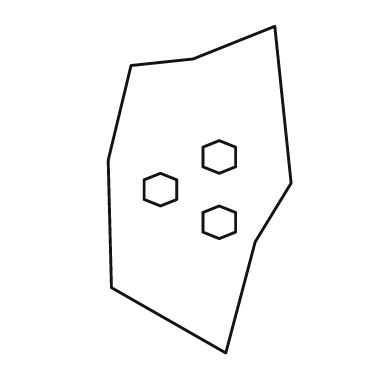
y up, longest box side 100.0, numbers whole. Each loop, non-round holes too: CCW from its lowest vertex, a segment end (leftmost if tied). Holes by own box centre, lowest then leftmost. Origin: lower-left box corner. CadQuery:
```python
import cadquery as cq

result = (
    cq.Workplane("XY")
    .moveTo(36.0, 0.0)
    .lineTo(45.0, 34.0)
    .lineTo(56.0, 52.0)
    .lineTo(51.0, 100.0)
    .lineTo(26.0, 90.0)
    .lineTo(7.0, 88.0)
    .lineTo(0.0, 59.0)
    .lineTo(1.0, 20.0)
    .close()
    .moveTo(34.0, 35.0)
    .lineTo(39.0, 37.0)
    .lineTo(39.0, 43.0)
    .lineTo(34.0, 45.0)
    .lineTo(29.0, 43.0)
    .lineTo(29.0, 37.0)
    .close()
    .moveTo(16.0, 45.0)
    .lineTo(21.0, 47.0)
    .lineTo(21.0, 53.0)
    .lineTo(16.0, 55.0)
    .lineTo(11.0, 53.0)
    .lineTo(11.0, 47.0)
    .close()
    .moveTo(34.0, 55.0)
    .lineTo(39.0, 57.0)
    .lineTo(39.0, 63.0)
    .lineTo(34.0, 65.0)
    .lineTo(29.0, 63.0)
    .lineTo(29.0, 57.0)
    .close()
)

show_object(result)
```